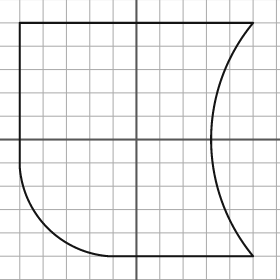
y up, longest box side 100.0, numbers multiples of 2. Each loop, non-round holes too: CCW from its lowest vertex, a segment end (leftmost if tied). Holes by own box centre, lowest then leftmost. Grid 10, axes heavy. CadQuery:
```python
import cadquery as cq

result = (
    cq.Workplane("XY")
    .moveTo(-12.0, -50.0)
    .lineTo(50.0, -50.0)
    .threePointArc((32.0, 0.0), (50.0, 50.0))
    .lineTo(-50.0, 50.0)
    .lineTo(-50.0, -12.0)
    .threePointArc((-38.0, -38.0), (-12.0, -50.0))
    .close()
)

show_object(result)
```